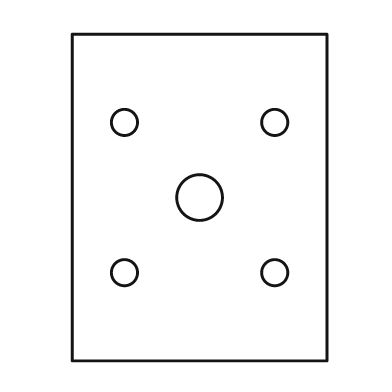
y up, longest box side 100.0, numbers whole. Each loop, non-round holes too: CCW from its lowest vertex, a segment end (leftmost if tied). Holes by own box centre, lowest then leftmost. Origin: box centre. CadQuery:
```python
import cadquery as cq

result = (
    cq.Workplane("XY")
    .moveTo(-39.0, -50.0)
    .lineTo(39.0, -50.0)
    .lineTo(39.0, 50.0)
    .lineTo(-39.0, 50.0)
    .close()
    .moveTo(-23.0, -23.0)
    .circle(4.0)
    .moveTo(23.0, -23.0)
    .circle(4.0)
    .moveTo(0.0, 0.0)
    .circle(7.0)
    .moveTo(-23.0, 23.0)
    .circle(4.0)
    .moveTo(23.0, 23.0)
    .circle(4.0)
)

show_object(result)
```